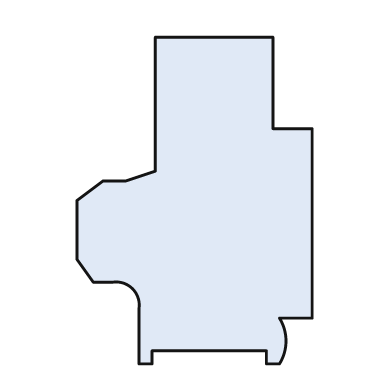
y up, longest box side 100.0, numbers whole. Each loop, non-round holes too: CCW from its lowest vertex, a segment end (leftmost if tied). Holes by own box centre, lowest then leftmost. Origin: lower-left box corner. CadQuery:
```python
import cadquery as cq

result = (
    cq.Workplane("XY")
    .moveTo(19.0, 0.0)
    .lineTo(23.0, 0.0)
    .lineTo(23.0, 4.0)
    .lineTo(58.0, 4.0)
    .lineTo(58.0, 0.0)
    .lineTo(62.0, 0.0)
    .threePointArc((64.0, 7.0), (62.0, 14.0))
    .lineTo(72.0, 14.0)
    .lineTo(72.0, 72.0)
    .lineTo(60.0, 72.0)
    .lineTo(60.0, 100.0)
    .lineTo(24.0, 100.0)
    .lineTo(24.0, 59.0)
    .lineTo(15.0, 56.0)
    .lineTo(8.0, 56.0)
    .lineTo(0.0, 50.0)
    .lineTo(0.0, 32.0)
    .lineTo(5.0, 25.0)
    .lineTo(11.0, 25.0)
    .threePointArc((17.0, 23.0), (19.0, 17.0))
    .close()
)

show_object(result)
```